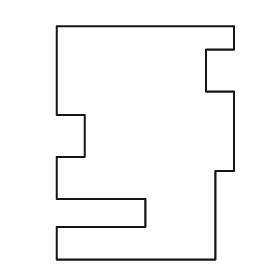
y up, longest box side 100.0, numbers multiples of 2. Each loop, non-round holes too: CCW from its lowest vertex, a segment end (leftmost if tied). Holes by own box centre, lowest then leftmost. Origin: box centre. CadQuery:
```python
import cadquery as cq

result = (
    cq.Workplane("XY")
    .moveTo(-38.0, -50.0)
    .lineTo(30.0, -50.0)
    .lineTo(30.0, -12.0)
    .lineTo(38.0, -12.0)
    .lineTo(38.0, 22.0)
    .lineTo(26.0, 22.0)
    .lineTo(26.0, 40.0)
    .lineTo(38.0, 40.0)
    .lineTo(38.0, 50.0)
    .lineTo(-38.0, 50.0)
    .lineTo(-38.0, 12.0)
    .lineTo(-26.0, 12.0)
    .lineTo(-26.0, -6.0)
    .lineTo(-38.0, -6.0)
    .lineTo(-38.0, -24.0)
    .lineTo(0.0, -24.0)
    .lineTo(0.0, -36.0)
    .lineTo(-38.0, -36.0)
    .close()
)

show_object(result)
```